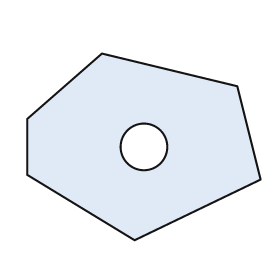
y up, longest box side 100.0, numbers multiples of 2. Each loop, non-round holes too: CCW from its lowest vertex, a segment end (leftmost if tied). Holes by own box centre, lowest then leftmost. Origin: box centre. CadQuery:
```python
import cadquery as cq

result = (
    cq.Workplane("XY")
    .moveTo(-4.0, -40.0)
    .lineTo(50.0, -14.0)
    .lineTo(40.0, 26.0)
    .lineTo(-18.0, 40.0)
    .lineTo(-50.0, 12.0)
    .lineTo(-50.0, -12.0)
    .close()
    .moveTo(0.0, 0.0)
    .circle(10.0)
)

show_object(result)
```